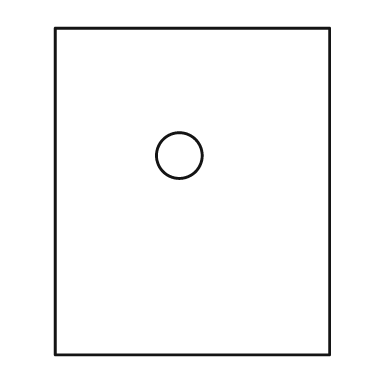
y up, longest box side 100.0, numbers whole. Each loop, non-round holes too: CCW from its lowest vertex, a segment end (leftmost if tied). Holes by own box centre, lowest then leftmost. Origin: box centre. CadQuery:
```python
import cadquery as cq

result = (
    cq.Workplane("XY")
    .moveTo(-42.0, -50.0)
    .lineTo(42.0, -50.0)
    .lineTo(42.0, 50.0)
    .lineTo(-42.0, 50.0)
    .close()
    .moveTo(-4.0, 11.0)
    .circle(7.0)
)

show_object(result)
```